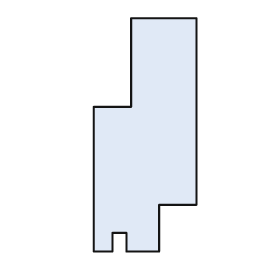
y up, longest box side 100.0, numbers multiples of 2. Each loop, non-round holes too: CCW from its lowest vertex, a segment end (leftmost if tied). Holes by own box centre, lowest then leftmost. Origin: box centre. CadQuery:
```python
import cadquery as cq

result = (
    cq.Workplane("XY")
    .moveTo(-22.0, -50.0)
    .lineTo(-14.0, -50.0)
    .lineTo(-14.0, -42.0)
    .lineTo(-8.0, -42.0)
    .lineTo(-8.0, -50.0)
    .lineTo(6.0, -50.0)
    .lineTo(6.0, -30.0)
    .lineTo(22.0, -30.0)
    .lineTo(22.0, 50.0)
    .lineTo(-6.0, 50.0)
    .lineTo(-6.0, 12.0)
    .lineTo(-22.0, 12.0)
    .close()
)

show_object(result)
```